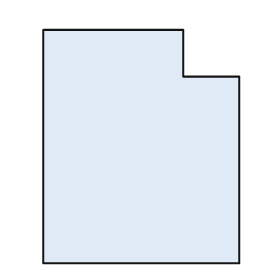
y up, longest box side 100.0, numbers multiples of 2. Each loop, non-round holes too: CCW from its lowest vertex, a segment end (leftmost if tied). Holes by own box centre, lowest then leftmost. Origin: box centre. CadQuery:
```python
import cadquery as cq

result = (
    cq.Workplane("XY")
    .moveTo(-42.0, -50.0)
    .lineTo(42.0, -50.0)
    .lineTo(42.0, 30.0)
    .lineTo(18.0, 30.0)
    .lineTo(18.0, 50.0)
    .lineTo(-42.0, 50.0)
    .close()
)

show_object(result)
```